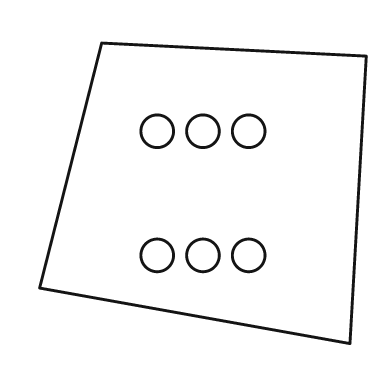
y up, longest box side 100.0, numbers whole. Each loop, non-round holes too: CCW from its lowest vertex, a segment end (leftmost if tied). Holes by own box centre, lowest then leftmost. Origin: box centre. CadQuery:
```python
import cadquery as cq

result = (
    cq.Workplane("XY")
    .moveTo(45.0, -46.0)
    .lineTo(50.0, 42.0)
    .lineTo(-31.0, 46.0)
    .lineTo(-50.0, -29.0)
    .close()
    .moveTo(-14.0, -19.0)
    .circle(5.0)
    .moveTo(0.0, -19.0)
    .circle(5.0)
    .moveTo(14.0, -19.0)
    .circle(5.0)
    .moveTo(-14.0, 19.0)
    .circle(5.0)
    .moveTo(0.0, 19.0)
    .circle(5.0)
    .moveTo(14.0, 19.0)
    .circle(5.0)
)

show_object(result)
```